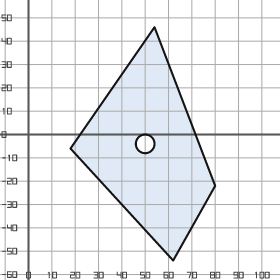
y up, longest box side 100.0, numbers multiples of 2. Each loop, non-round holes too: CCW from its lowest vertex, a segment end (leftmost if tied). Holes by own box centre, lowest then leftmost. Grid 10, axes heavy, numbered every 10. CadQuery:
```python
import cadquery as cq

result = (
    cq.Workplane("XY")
    .moveTo(62.0, -54.0)
    .lineTo(80.0, -22.0)
    .lineTo(54.0, 46.0)
    .lineTo(18.0, -6.0)
    .close()
    .moveTo(50.0, -4.0)
    .circle(4.0)
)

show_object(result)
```